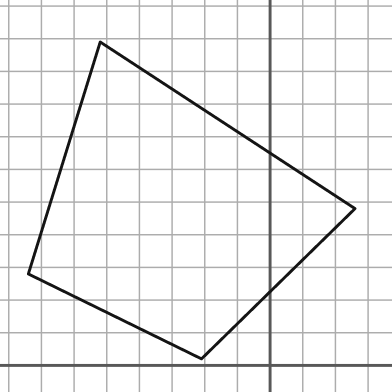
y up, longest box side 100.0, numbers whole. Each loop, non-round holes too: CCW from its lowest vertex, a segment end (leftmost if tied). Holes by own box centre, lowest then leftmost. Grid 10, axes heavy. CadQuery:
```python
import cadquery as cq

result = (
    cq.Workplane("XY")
    .moveTo(-21.0, 2.0)
    .lineTo(26.0, 48.0)
    .lineTo(-52.0, 99.0)
    .lineTo(-74.0, 28.0)
    .close()
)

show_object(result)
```